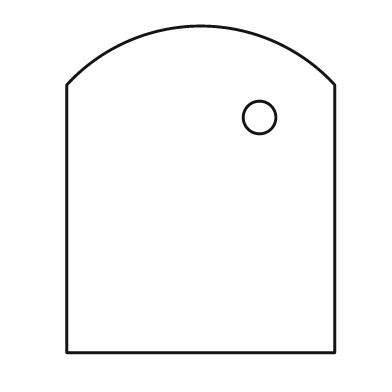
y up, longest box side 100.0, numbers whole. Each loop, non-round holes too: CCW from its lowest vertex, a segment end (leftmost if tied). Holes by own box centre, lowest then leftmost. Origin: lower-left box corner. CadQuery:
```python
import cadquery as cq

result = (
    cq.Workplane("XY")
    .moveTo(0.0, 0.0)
    .lineTo(82.0, 0.0)
    .lineTo(82.0, 82.0)
    .threePointArc((41.0, 100.0), (0.0, 82.0))
    .close()
    .moveTo(59.0, 72.0)
    .circle(5.0)
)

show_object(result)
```